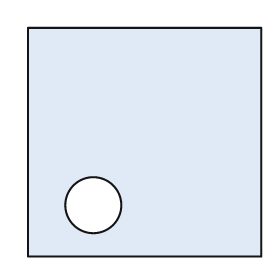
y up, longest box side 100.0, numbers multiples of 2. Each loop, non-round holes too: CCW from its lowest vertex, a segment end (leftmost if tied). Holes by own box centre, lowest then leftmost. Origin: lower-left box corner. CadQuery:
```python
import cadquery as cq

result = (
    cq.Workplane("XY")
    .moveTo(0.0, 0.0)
    .lineTo(100.0, 0.0)
    .lineTo(100.0, 98.0)
    .lineTo(0.0, 98.0)
    .close()
    .moveTo(28.0, 22.0)
    .circle(12.0)
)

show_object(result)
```